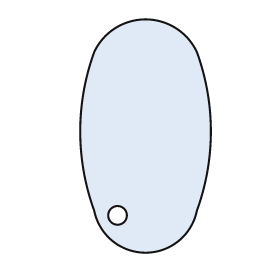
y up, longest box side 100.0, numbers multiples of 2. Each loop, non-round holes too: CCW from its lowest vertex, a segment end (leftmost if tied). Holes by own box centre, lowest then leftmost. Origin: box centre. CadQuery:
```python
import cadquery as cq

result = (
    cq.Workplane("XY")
    .moveTo(-22.0, -32.0)
    .threePointArc((0.0, -50.0), (22.0, -32.0))
    .threePointArc((28.0, 2.0), (22.0, 36.0))
    .threePointArc((0.0, 50.0), (-22.0, 36.0))
    .threePointArc((-28.0, 2.0), (-22.0, -32.0))
    .close()
    .moveTo(-12.0, -34.0)
    .circle(4.0)
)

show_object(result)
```